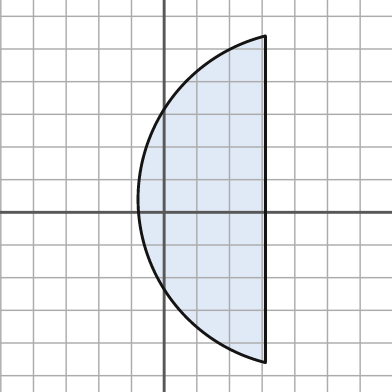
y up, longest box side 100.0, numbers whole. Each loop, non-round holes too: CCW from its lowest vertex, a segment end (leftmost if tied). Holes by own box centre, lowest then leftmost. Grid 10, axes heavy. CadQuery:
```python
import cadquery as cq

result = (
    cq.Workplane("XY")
    .moveTo(31.0, -46.0)
    .lineTo(31.0, 54.0)
    .threePointArc((-8.0, 4.0), (31.0, -46.0))
    .close()
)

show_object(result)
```